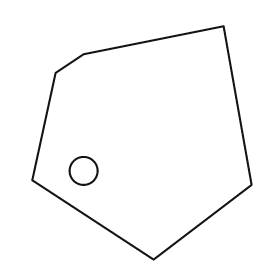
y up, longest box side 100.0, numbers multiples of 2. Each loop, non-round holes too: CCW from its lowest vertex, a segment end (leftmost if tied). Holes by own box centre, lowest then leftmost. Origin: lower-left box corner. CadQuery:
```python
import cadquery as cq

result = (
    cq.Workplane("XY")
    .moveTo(52.0, 0.0)
    .lineTo(94.0, 32.0)
    .lineTo(82.0, 100.0)
    .lineTo(22.0, 88.0)
    .lineTo(10.0, 80.0)
    .lineTo(0.0, 34.0)
    .close()
    .moveTo(22.0, 38.0)
    .circle(6.0)
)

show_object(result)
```